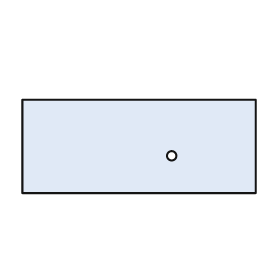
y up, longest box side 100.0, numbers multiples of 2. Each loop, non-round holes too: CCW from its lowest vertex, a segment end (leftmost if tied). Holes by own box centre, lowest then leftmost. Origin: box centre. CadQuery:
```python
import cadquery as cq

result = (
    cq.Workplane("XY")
    .moveTo(-50.0, -20.0)
    .lineTo(50.0, -20.0)
    .lineTo(50.0, 20.0)
    .lineTo(-50.0, 20.0)
    .close()
    .moveTo(14.0, -4.0)
    .circle(2.0)
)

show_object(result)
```